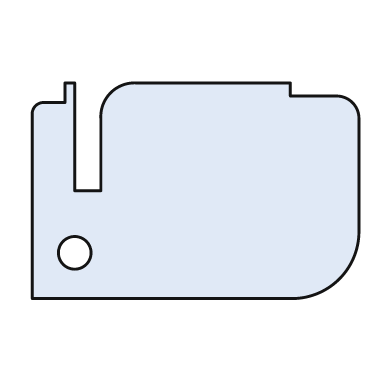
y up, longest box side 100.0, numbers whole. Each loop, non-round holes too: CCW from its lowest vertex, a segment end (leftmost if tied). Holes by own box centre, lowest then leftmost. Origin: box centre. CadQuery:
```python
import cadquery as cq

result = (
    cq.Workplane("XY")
    .moveTo(-50.0, -33.0)
    .lineTo(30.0, -33.0)
    .threePointArc((44.0, -27.0), (50.0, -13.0))
    .lineTo(50.0, 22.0)
    .threePointArc((48.0, 27.0), (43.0, 29.0))
    .lineTo(29.0, 29.0)
    .lineTo(29.0, 33.0)
    .lineTo(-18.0, 33.0)
    .threePointArc((-26.0, 30.0), (-29.0, 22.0))
    .lineTo(-29.0, 0.0)
    .lineTo(-37.0, 0.0)
    .lineTo(-37.0, 33.0)
    .lineTo(-40.0, 33.0)
    .lineTo(-40.0, 27.0)
    .lineTo(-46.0, 27.0)
    .threePointArc((-49.0, 26.0), (-50.0, 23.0))
    .close()
    .moveTo(-37.0, -19.0)
    .circle(5.0)
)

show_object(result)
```